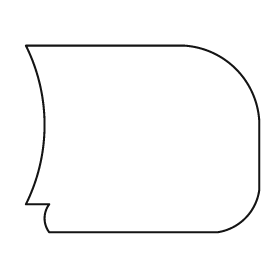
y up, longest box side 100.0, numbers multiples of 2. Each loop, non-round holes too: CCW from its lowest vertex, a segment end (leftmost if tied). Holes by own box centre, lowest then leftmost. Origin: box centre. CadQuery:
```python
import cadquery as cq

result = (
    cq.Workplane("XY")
    .moveTo(-40.0, -40.0)
    .lineTo(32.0, -40.0)
    .threePointArc((44.0, -34.0), (50.0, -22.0))
    .lineTo(50.0, 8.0)
    .threePointArc((40.0, 30.0), (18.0, 40.0))
    .lineTo(-50.0, 40.0)
    .threePointArc((-42.0, 6.0), (-50.0, -28.0))
    .lineTo(-40.0, -28.0)
    .threePointArc((-42.0, -34.0), (-40.0, -40.0))
    .close()
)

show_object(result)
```